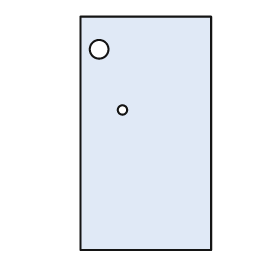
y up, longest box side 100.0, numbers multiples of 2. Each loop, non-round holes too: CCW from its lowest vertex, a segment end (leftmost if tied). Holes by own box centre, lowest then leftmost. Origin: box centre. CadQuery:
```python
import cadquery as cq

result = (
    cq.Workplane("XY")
    .moveTo(-28.0, -50.0)
    .lineTo(28.0, -50.0)
    .lineTo(28.0, 50.0)
    .lineTo(-28.0, 50.0)
    .close()
    .moveTo(-10.0, 10.0)
    .circle(2.0)
    .moveTo(-20.0, 36.0)
    .circle(4.0)
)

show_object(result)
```